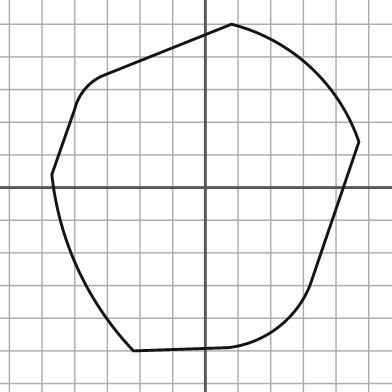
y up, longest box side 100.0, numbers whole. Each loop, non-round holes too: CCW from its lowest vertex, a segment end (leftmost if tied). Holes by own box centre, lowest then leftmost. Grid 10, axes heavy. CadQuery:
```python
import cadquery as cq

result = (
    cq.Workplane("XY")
    .moveTo(-22.0, -50.0)
    .lineTo(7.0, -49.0)
    .threePointArc((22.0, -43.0), (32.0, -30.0))
    .lineTo(47.0, 14.0)
    .threePointArc((32.0, 37.0), (8.0, 50.0))
    .lineTo(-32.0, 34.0)
    .threePointArc((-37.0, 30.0), (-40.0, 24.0))
    .lineTo(-47.0, 4.0)
    .threePointArc((-39.0, -25.0), (-22.0, -50.0))
    .close()
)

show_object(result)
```